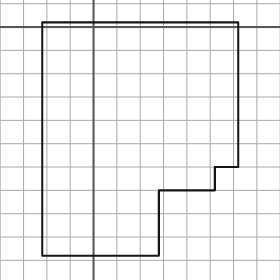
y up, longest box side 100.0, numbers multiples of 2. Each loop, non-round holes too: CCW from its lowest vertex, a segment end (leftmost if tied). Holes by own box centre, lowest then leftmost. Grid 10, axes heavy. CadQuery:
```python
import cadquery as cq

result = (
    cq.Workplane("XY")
    .moveTo(-22.0, -98.0)
    .lineTo(28.0, -98.0)
    .lineTo(28.0, -70.0)
    .lineTo(52.0, -70.0)
    .lineTo(52.0, -60.0)
    .lineTo(62.0, -60.0)
    .lineTo(62.0, 2.0)
    .lineTo(-22.0, 2.0)
    .close()
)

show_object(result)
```